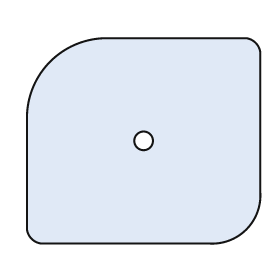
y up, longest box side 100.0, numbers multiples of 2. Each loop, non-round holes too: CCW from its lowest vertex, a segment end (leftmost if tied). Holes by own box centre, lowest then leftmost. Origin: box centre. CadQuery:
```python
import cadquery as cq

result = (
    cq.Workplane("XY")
    .moveTo(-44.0, -44.0)
    .lineTo(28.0, -44.0)
    .threePointArc((44.0, -38.0), (50.0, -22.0))
    .lineTo(50.0, 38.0)
    .threePointArc((48.0, 42.0), (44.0, 44.0))
    .lineTo(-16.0, 44.0)
    .threePointArc((-40.0, 34.0), (-50.0, 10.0))
    .lineTo(-50.0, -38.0)
    .threePointArc((-48.0, -42.0), (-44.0, -44.0))
    .close()
    .moveTo(0.0, 0.0)
    .circle(4.0)
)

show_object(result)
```